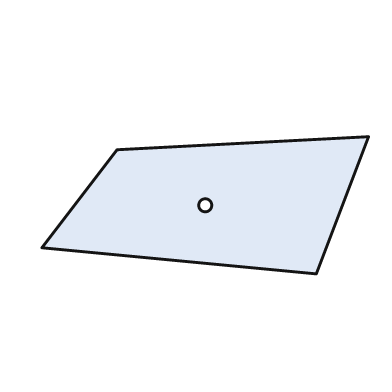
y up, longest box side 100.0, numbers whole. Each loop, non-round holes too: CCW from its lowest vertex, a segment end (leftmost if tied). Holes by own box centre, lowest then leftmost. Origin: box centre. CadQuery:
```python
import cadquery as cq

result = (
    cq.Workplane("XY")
    .moveTo(34.0, -21.0)
    .lineTo(50.0, 21.0)
    .lineTo(-27.0, 17.0)
    .lineTo(-50.0, -13.0)
    .close()
    .moveTo(0.0, 0.0)
    .circle(2.0)
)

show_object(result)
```